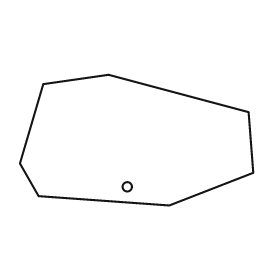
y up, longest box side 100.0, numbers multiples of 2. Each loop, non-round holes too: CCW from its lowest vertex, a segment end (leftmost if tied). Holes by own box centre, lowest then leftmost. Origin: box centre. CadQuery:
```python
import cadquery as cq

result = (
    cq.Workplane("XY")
    .moveTo(14.0, -28.0)
    .lineTo(50.0, -14.0)
    .lineTo(48.0, 12.0)
    .lineTo(-12.0, 28.0)
    .lineTo(-40.0, 24.0)
    .lineTo(-50.0, -10.0)
    .lineTo(-42.0, -24.0)
    .close()
    .moveTo(-4.0, -20.0)
    .circle(2.0)
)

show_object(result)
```